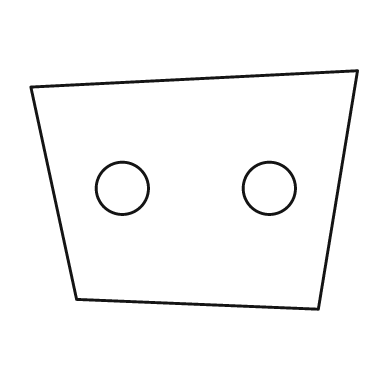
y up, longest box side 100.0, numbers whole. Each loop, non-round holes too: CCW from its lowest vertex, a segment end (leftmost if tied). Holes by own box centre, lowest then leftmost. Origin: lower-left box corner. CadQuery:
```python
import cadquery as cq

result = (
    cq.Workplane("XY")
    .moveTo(88.0, 0.0)
    .lineTo(100.0, 73.0)
    .lineTo(0.0, 68.0)
    .lineTo(14.0, 3.0)
    .close()
    .moveTo(28.0, 37.0)
    .circle(8.0)
    .moveTo(73.0, 37.0)
    .circle(8.0)
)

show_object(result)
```